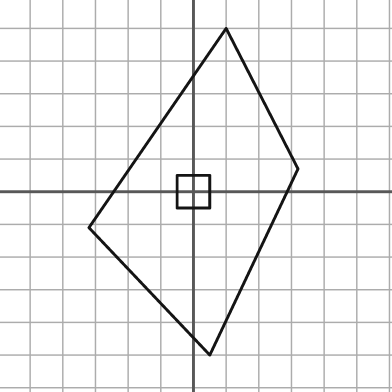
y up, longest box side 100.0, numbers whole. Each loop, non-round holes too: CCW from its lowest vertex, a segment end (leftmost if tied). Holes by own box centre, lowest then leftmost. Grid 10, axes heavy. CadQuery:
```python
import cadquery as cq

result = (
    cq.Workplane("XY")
    .moveTo(5.0, -50.0)
    .lineTo(32.0, 7.0)
    .lineTo(10.0, 50.0)
    .lineTo(-32.0, -11.0)
    .close()
    .moveTo(-5.0, -5.0)
    .lineTo(5.0, -5.0)
    .lineTo(5.0, 5.0)
    .lineTo(-5.0, 5.0)
    .close()
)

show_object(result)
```